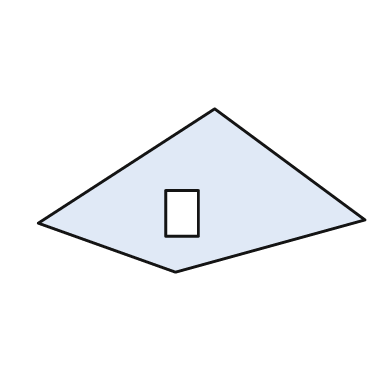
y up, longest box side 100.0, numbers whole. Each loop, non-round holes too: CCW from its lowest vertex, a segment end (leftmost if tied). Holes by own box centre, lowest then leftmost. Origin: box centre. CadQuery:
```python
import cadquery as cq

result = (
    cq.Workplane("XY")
    .moveTo(-8.0, -25.0)
    .lineTo(50.0, -9.0)
    .lineTo(4.0, 25.0)
    .lineTo(-50.0, -10.0)
    .close()
    .moveTo(-11.0, -14.0)
    .lineTo(-1.0, -14.0)
    .lineTo(-1.0, 0.0)
    .lineTo(-11.0, 0.0)
    .close()
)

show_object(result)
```